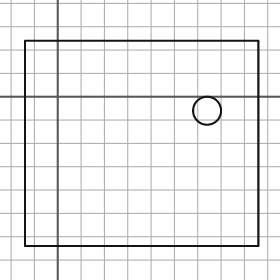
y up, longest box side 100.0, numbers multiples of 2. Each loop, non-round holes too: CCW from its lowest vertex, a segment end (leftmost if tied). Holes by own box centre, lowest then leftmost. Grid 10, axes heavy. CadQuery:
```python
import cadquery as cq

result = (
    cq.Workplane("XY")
    .moveTo(-14.0, -64.0)
    .lineTo(86.0, -64.0)
    .lineTo(86.0, 24.0)
    .lineTo(-14.0, 24.0)
    .close()
    .moveTo(64.0, -6.0)
    .circle(6.0)
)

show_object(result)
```